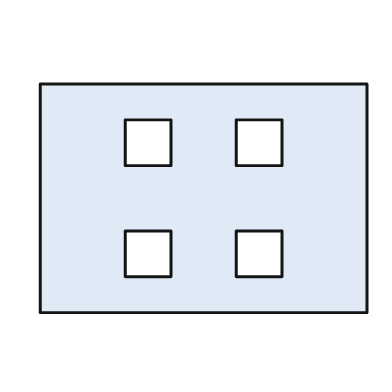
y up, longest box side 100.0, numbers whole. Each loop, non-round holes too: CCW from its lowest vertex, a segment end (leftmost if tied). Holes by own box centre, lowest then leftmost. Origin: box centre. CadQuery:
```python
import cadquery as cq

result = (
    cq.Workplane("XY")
    .moveTo(-50.0, -35.0)
    .lineTo(50.0, -35.0)
    .lineTo(50.0, 35.0)
    .lineTo(-50.0, 35.0)
    .close()
    .moveTo(-24.0, -24.0)
    .lineTo(-10.0, -24.0)
    .lineTo(-10.0, -10.0)
    .lineTo(-24.0, -10.0)
    .close()
    .moveTo(10.0, -24.0)
    .lineTo(24.0, -24.0)
    .lineTo(24.0, -10.0)
    .lineTo(10.0, -10.0)
    .close()
    .moveTo(-24.0, 10.0)
    .lineTo(-10.0, 10.0)
    .lineTo(-10.0, 24.0)
    .lineTo(-24.0, 24.0)
    .close()
    .moveTo(10.0, 10.0)
    .lineTo(24.0, 10.0)
    .lineTo(24.0, 24.0)
    .lineTo(10.0, 24.0)
    .close()
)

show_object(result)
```